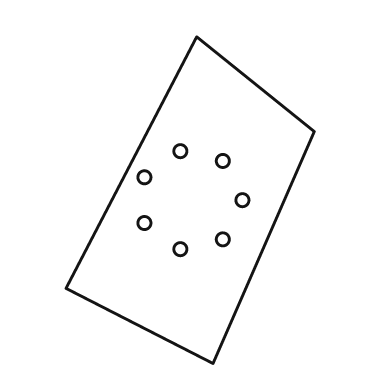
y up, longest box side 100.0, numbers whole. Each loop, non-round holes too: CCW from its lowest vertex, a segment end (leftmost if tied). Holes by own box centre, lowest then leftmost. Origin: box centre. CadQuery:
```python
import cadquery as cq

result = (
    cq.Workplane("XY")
    .moveTo(7.0, -50.0)
    .lineTo(38.0, 21.0)
    .lineTo(2.0, 50.0)
    .lineTo(-38.0, -27.0)
    .close()
    .moveTo(-3.0, -15.0)
    .circle(2.0)
    .moveTo(10.0, -12.0)
    .circle(2.0)
    .moveTo(-14.0, -7.0)
    .circle(2.0)
    .moveTo(16.0, 0.0)
    .circle(2.0)
    .moveTo(-14.0, 7.0)
    .circle(2.0)
    .moveTo(10.0, 12.0)
    .circle(2.0)
    .moveTo(-3.0, 15.0)
    .circle(2.0)
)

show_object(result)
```